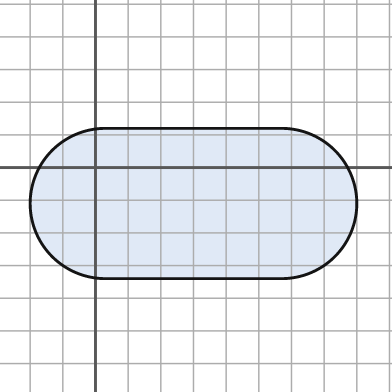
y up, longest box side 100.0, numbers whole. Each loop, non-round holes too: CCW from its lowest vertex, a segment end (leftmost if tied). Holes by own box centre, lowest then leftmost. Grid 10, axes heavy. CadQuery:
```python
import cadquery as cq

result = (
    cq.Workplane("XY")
    .moveTo(3.0, -34.0)
    .lineTo(57.0, -34.0)
    .threePointArc((80.0, -11.0), (57.0, 12.0))
    .lineTo(3.0, 12.0)
    .threePointArc((-20.0, -11.0), (3.0, -34.0))
    .close()
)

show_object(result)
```